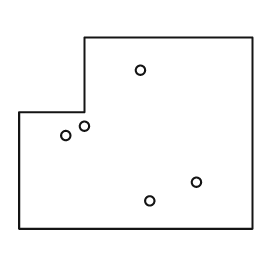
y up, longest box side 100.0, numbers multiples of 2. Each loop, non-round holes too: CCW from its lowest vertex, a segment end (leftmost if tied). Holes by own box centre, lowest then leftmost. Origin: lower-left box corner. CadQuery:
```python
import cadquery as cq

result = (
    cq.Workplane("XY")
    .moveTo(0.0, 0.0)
    .lineTo(100.0, 0.0)
    .lineTo(100.0, 82.0)
    .lineTo(28.0, 82.0)
    .lineTo(28.0, 50.0)
    .lineTo(0.0, 50.0)
    .close()
    .moveTo(56.0, 12.0)
    .circle(2.0)
    .moveTo(76.0, 20.0)
    .circle(2.0)
    .moveTo(20.0, 40.0)
    .circle(2.0)
    .moveTo(28.0, 44.0)
    .circle(2.0)
    .moveTo(52.0, 68.0)
    .circle(2.0)
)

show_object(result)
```